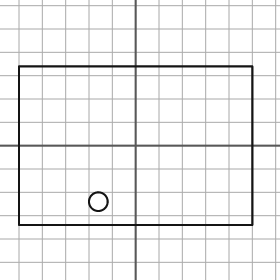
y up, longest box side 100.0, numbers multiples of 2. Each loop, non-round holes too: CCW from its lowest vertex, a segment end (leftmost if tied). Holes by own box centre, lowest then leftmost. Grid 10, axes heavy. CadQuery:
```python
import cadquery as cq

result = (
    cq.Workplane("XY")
    .moveTo(-50.0, -34.0)
    .lineTo(50.0, -34.0)
    .lineTo(50.0, 34.0)
    .lineTo(-50.0, 34.0)
    .close()
    .moveTo(-16.0, -24.0)
    .circle(4.0)
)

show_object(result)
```